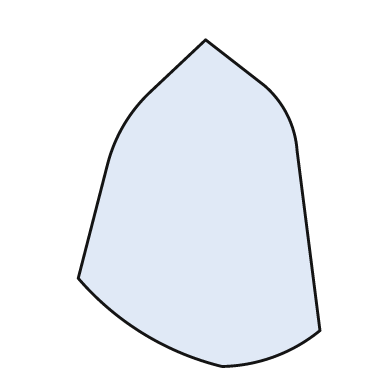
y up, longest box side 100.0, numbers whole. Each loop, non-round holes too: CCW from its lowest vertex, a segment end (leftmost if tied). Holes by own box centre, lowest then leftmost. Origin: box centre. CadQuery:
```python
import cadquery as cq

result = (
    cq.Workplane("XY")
    .moveTo(7.0, -50.0)
    .threePointArc((23.0, -47.0), (37.0, -39.0))
    .lineTo(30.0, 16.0)
    .threePointArc((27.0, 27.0), (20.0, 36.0))
    .lineTo(2.0, 50.0)
    .lineTo(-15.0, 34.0)
    .threePointArc((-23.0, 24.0), (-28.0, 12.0))
    .lineTo(-37.0, -23.0)
    .threePointArc((-17.0, -40.0), (7.0, -50.0))
    .close()
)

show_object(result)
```